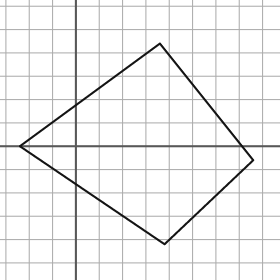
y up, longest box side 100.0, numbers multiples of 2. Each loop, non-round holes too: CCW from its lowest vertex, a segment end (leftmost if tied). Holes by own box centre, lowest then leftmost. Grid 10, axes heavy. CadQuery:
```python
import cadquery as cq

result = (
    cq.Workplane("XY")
    .moveTo(38.0, -42.0)
    .lineTo(76.0, -6.0)
    .lineTo(36.0, 44.0)
    .lineTo(-24.0, 0.0)
    .close()
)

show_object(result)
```